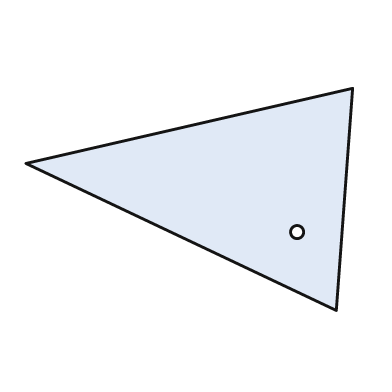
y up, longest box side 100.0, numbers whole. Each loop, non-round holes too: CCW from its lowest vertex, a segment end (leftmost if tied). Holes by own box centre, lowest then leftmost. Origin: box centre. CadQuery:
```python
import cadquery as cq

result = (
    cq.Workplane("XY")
    .moveTo(45.0, -34.0)
    .lineTo(50.0, 34.0)
    .lineTo(-50.0, 11.0)
    .close()
    .moveTo(33.0, -10.0)
    .circle(2.0)
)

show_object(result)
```